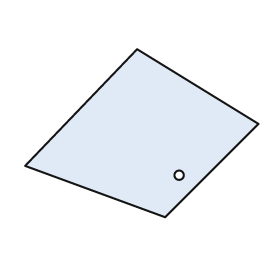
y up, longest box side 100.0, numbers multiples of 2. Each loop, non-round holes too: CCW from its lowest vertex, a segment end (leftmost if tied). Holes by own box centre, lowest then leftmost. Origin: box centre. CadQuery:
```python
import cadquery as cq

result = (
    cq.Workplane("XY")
    .moveTo(10.0, -36.0)
    .lineTo(50.0, 4.0)
    .lineTo(-2.0, 36.0)
    .lineTo(-50.0, -14.0)
    .close()
    .moveTo(16.0, -18.0)
    .circle(2.0)
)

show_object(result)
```